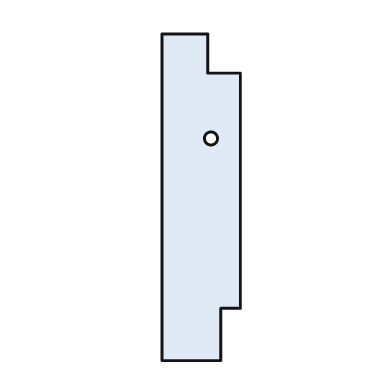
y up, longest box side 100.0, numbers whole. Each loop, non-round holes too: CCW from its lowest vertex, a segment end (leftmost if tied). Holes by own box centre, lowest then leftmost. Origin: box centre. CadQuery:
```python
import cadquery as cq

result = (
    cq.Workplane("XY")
    .moveTo(-12.0, -50.0)
    .lineTo(6.0, -50.0)
    .lineTo(6.0, -34.0)
    .lineTo(12.0, -34.0)
    .lineTo(12.0, 38.0)
    .lineTo(2.0, 38.0)
    .lineTo(2.0, 50.0)
    .lineTo(-12.0, 50.0)
    .close()
    .moveTo(3.0, 18.0)
    .circle(2.0)
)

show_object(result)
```